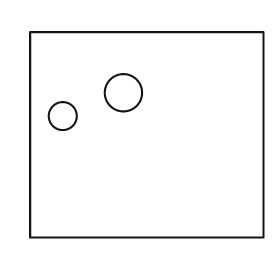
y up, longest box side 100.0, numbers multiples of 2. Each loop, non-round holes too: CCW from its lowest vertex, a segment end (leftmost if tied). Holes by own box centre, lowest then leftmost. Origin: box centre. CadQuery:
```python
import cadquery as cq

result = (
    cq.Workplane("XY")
    .moveTo(-50.0, -44.0)
    .lineTo(50.0, -44.0)
    .lineTo(50.0, 44.0)
    .lineTo(-50.0, 44.0)
    .close()
    .moveTo(-36.0, 8.0)
    .circle(6.0)
    .moveTo(-10.0, 18.0)
    .circle(8.0)
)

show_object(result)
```